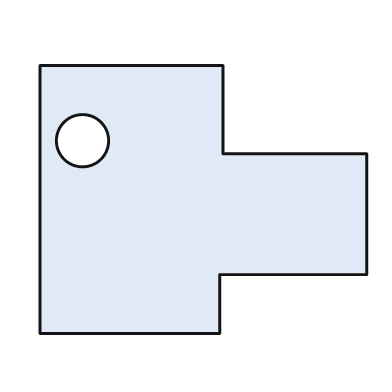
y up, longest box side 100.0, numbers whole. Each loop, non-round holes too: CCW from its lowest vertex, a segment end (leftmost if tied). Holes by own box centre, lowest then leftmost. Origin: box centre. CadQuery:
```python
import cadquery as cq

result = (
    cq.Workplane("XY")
    .moveTo(-50.0, -41.0)
    .lineTo(5.0, -41.0)
    .lineTo(5.0, -23.0)
    .lineTo(50.0, -23.0)
    .lineTo(50.0, 14.0)
    .lineTo(6.0, 14.0)
    .lineTo(6.0, 41.0)
    .lineTo(-50.0, 41.0)
    .close()
    .moveTo(-37.0, 18.0)
    .circle(8.0)
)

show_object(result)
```